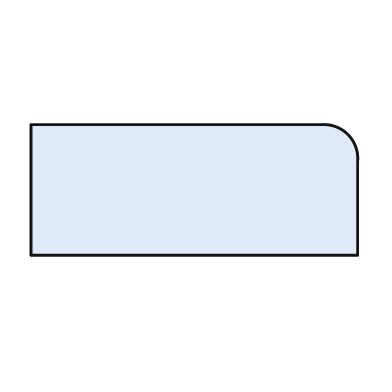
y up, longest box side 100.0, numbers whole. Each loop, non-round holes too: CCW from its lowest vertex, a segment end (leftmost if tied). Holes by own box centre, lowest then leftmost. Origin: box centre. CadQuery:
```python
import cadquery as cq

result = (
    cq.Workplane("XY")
    .moveTo(-50.0, -20.0)
    .lineTo(50.0, -20.0)
    .lineTo(50.0, 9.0)
    .threePointArc((47.0, 17.0), (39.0, 20.0))
    .lineTo(-50.0, 20.0)
    .close()
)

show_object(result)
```